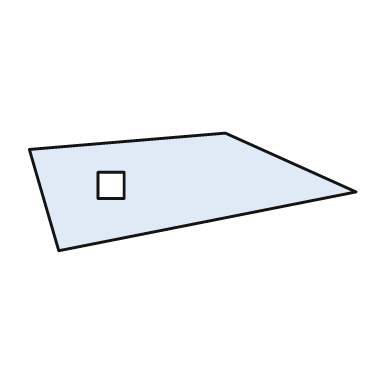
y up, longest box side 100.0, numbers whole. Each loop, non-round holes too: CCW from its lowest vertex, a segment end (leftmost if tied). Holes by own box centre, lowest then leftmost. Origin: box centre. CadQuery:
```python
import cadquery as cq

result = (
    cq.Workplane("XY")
    .moveTo(-41.0, -18.0)
    .lineTo(50.0, 0.0)
    .lineTo(10.0, 18.0)
    .lineTo(-50.0, 13.0)
    .close()
    .moveTo(-29.0, -2.0)
    .lineTo(-21.0, -2.0)
    .lineTo(-21.0, 6.0)
    .lineTo(-29.0, 6.0)
    .close()
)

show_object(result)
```